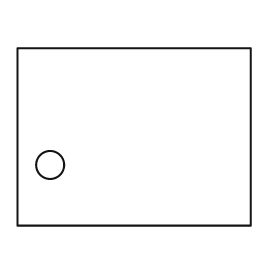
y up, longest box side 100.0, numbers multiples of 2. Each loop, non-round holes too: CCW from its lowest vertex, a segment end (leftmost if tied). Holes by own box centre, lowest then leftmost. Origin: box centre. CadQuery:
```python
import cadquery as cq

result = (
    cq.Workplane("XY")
    .moveTo(-50.0, -38.0)
    .lineTo(50.0, -38.0)
    .lineTo(50.0, 38.0)
    .lineTo(-50.0, 38.0)
    .close()
    .moveTo(-36.0, -12.0)
    .circle(6.0)
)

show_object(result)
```